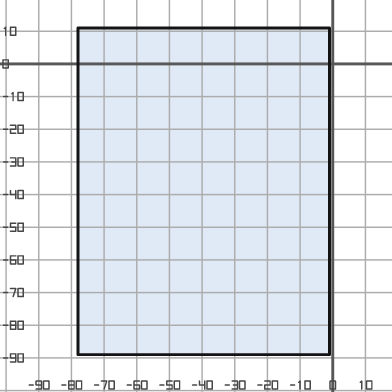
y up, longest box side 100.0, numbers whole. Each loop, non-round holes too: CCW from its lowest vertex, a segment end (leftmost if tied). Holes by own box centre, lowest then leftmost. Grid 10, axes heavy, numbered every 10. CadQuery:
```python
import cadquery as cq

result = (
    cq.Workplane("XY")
    .moveTo(-78.0, -89.0)
    .lineTo(-1.0, -89.0)
    .lineTo(-1.0, 11.0)
    .lineTo(-78.0, 11.0)
    .close()
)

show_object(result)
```